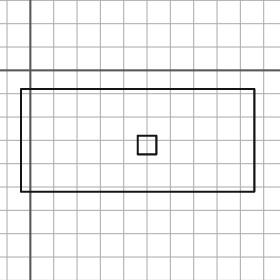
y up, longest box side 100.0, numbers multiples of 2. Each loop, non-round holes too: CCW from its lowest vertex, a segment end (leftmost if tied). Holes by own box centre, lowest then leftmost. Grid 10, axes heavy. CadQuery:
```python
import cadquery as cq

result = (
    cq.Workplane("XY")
    .moveTo(-4.0, -52.0)
    .lineTo(96.0, -52.0)
    .lineTo(96.0, -8.0)
    .lineTo(-4.0, -8.0)
    .close()
    .moveTo(46.0, -36.0)
    .lineTo(54.0, -36.0)
    .lineTo(54.0, -28.0)
    .lineTo(46.0, -28.0)
    .close()
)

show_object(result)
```